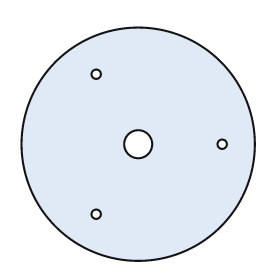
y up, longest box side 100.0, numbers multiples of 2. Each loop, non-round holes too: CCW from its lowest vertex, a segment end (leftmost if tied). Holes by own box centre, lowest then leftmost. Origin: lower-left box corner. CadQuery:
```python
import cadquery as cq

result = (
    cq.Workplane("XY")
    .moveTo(50.0, 50.0)
    .circle(50.0)
    .moveTo(32.0, 20.0)
    .circle(2.0)
    .moveTo(50.0, 50.0)
    .circle(6.0)
    .moveTo(86.0, 50.0)
    .circle(2.0)
    .moveTo(32.0, 80.0)
    .circle(2.0)
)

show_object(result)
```